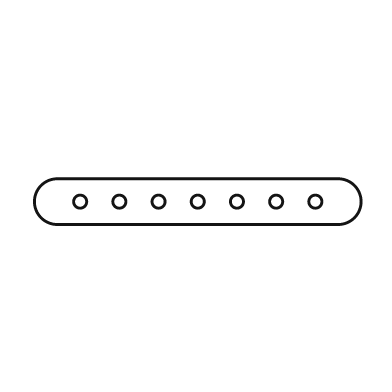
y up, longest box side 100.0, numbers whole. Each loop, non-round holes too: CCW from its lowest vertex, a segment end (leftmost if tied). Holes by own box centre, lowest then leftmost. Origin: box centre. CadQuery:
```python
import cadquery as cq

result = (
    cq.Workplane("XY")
    .moveTo(-43.0, -7.0)
    .lineTo(43.0, -7.0)
    .threePointArc((50.0, 0.0), (43.0, 7.0))
    .lineTo(-43.0, 7.0)
    .threePointArc((-50.0, 0.0), (-43.0, -7.0))
    .close()
    .moveTo(-36.0, 0.0)
    .circle(2.0)
    .moveTo(-24.0, 0.0)
    .circle(2.0)
    .moveTo(-12.0, 0.0)
    .circle(2.0)
    .moveTo(0.0, 0.0)
    .circle(2.0)
    .moveTo(12.0, 0.0)
    .circle(2.0)
    .moveTo(24.0, 0.0)
    .circle(2.0)
    .moveTo(36.0, 0.0)
    .circle(2.0)
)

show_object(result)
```